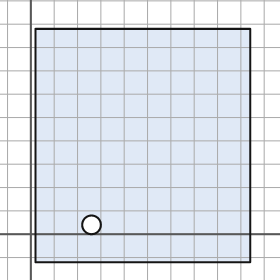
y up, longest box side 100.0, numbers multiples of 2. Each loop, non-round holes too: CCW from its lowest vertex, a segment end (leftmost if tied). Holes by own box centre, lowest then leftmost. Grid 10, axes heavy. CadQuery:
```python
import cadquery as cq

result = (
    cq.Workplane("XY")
    .moveTo(2.0, -12.0)
    .lineTo(94.0, -12.0)
    .lineTo(94.0, 88.0)
    .lineTo(2.0, 88.0)
    .close()
    .moveTo(26.0, 4.0)
    .circle(4.0)
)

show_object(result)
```